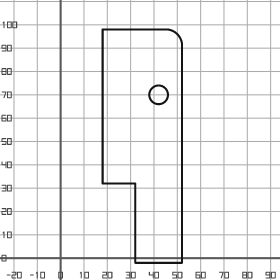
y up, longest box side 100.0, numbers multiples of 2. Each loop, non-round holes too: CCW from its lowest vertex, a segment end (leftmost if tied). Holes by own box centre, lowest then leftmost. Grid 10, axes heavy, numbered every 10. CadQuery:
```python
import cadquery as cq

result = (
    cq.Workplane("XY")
    .moveTo(32.0, -2.0)
    .lineTo(52.0, -2.0)
    .lineTo(52.0, 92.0)
    .threePointArc((50.0, 96.0), (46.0, 98.0))
    .lineTo(18.0, 98.0)
    .lineTo(18.0, 32.0)
    .lineTo(32.0, 32.0)
    .close()
    .moveTo(42.0, 70.0)
    .circle(4.0)
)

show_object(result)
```